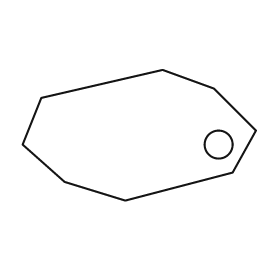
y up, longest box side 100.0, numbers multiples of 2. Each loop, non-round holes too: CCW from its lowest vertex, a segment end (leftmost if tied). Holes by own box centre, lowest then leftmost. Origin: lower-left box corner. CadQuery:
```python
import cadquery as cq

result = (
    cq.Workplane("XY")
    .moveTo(44.0, 0.0)
    .lineTo(90.0, 12.0)
    .lineTo(100.0, 30.0)
    .lineTo(82.0, 48.0)
    .lineTo(60.0, 56.0)
    .lineTo(8.0, 44.0)
    .lineTo(0.0, 24.0)
    .lineTo(18.0, 8.0)
    .close()
    .moveTo(84.0, 24.0)
    .circle(6.0)
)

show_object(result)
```